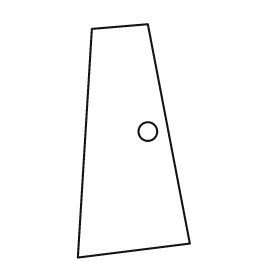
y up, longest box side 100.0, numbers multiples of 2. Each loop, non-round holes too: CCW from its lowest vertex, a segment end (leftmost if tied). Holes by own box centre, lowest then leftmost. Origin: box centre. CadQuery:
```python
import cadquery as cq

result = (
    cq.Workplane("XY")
    .moveTo(-24.0, -50.0)
    .lineTo(24.0, -44.0)
    .lineTo(6.0, 50.0)
    .lineTo(-18.0, 48.0)
    .close()
    .moveTo(6.0, 4.0)
    .circle(4.0)
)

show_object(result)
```